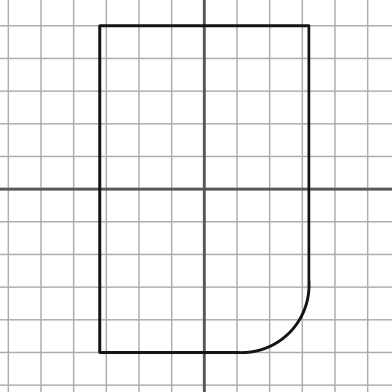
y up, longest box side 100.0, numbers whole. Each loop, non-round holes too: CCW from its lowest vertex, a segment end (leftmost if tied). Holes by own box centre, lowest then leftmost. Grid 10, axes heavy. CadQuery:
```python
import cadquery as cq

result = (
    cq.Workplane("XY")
    .moveTo(-32.0, -50.0)
    .lineTo(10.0, -50.0)
    .threePointArc((26.0, -44.0), (32.0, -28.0))
    .lineTo(32.0, 50.0)
    .lineTo(-32.0, 50.0)
    .close()
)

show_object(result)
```